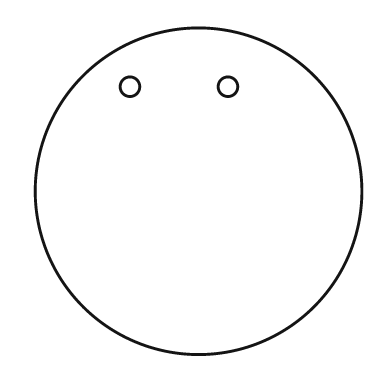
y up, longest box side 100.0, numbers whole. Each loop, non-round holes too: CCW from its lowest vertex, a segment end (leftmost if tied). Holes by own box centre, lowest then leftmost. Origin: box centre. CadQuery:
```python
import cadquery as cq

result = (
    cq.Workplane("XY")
    .moveTo(0.0, 0.0)
    .circle(50.0)
    .moveTo(-21.0, 32.0)
    .circle(3.0)
    .moveTo(9.0, 32.0)
    .circle(3.0)
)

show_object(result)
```